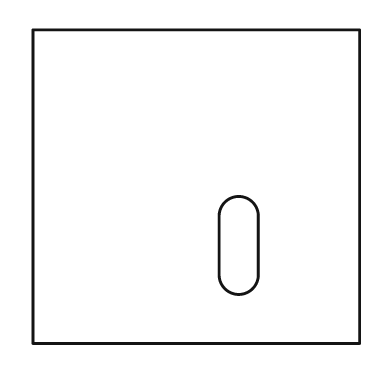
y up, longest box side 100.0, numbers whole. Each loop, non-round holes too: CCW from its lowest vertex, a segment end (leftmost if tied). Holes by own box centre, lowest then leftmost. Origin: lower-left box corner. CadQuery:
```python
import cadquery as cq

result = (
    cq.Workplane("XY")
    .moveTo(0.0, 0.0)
    .lineTo(100.0, 0.0)
    .lineTo(100.0, 96.0)
    .lineTo(0.0, 96.0)
    .close()
    .moveTo(57.0, 21.0)
    .threePointArc((63.0, 15.0), (69.0, 21.0))
    .lineTo(69.0, 39.0)
    .threePointArc((63.0, 45.0), (57.0, 39.0))
    .close()
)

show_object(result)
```